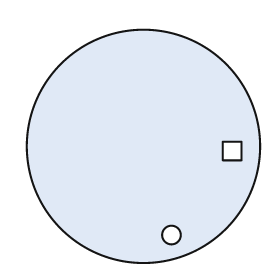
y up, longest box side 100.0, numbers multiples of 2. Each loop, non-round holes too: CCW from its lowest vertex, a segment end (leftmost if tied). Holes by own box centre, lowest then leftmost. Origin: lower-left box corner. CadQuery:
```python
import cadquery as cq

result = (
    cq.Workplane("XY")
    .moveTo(50.0, 50.0)
    .circle(50.0)
    .moveTo(62.0, 12.0)
    .circle(4.0)
    .moveTo(84.0, 44.0)
    .lineTo(92.0, 44.0)
    .lineTo(92.0, 52.0)
    .lineTo(84.0, 52.0)
    .close()
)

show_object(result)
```